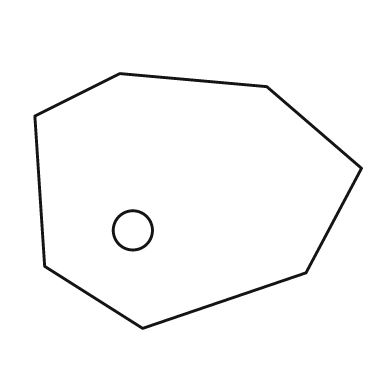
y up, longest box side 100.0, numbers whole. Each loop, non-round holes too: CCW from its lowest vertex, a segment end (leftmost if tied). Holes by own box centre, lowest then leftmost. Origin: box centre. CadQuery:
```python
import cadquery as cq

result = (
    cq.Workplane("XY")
    .moveTo(-17.0, -39.0)
    .lineTo(33.0, -22.0)
    .lineTo(50.0, 10.0)
    .lineTo(21.0, 35.0)
    .lineTo(-24.0, 39.0)
    .lineTo(-50.0, 26.0)
    .lineTo(-47.0, -20.0)
    .close()
    .moveTo(-20.0, -9.0)
    .circle(6.0)
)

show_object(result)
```